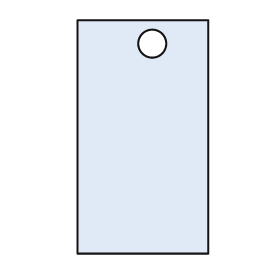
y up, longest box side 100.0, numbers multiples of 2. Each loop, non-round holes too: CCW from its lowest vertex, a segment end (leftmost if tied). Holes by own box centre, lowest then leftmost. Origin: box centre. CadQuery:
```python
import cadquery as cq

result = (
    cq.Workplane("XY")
    .moveTo(-28.0, -50.0)
    .lineTo(28.0, -50.0)
    .lineTo(28.0, 50.0)
    .lineTo(-28.0, 50.0)
    .close()
    .moveTo(4.0, 40.0)
    .circle(6.0)
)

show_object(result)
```